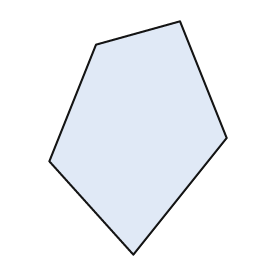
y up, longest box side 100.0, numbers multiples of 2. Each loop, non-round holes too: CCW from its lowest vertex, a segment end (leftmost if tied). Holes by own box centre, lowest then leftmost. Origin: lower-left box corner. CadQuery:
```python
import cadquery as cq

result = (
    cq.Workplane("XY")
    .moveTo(36.0, 0.0)
    .lineTo(76.0, 50.0)
    .lineTo(56.0, 100.0)
    .lineTo(20.0, 90.0)
    .lineTo(0.0, 40.0)
    .close()
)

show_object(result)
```